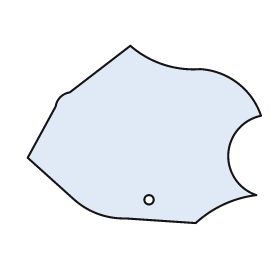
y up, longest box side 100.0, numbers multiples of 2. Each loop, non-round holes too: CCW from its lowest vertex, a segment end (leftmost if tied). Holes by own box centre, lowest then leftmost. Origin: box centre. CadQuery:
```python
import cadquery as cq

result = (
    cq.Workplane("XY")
    .moveTo(22.0, -38.0)
    .threePointArc((34.0, -30.0), (48.0, -26.0))
    .threePointArc((36.0, -8.0), (50.0, 8.0))
    .threePointArc((40.0, 22.0), (24.0, 28.0))
    .threePointArc((8.0, 30.0), (-6.0, 38.0))
    .lineTo(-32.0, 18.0)
    .threePointArc((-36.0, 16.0), (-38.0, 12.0))
    .lineTo(-50.0, -10.0)
    .lineTo(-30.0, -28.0)
    .threePointArc((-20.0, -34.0), (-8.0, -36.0))
    .close()
    .moveTo(2.0, -28.0)
    .circle(2.0)
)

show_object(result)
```